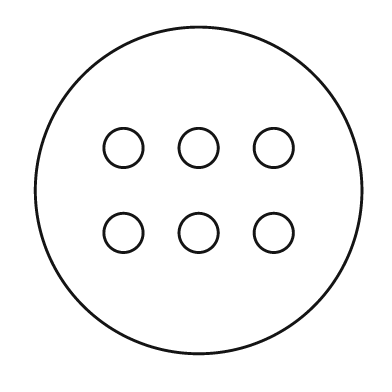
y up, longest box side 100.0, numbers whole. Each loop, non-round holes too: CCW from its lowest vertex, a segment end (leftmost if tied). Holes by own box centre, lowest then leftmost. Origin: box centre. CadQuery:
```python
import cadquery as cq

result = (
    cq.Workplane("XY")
    .moveTo(0.0, 0.0)
    .circle(50.0)
    .moveTo(-23.0, -13.0)
    .circle(6.0)
    .moveTo(0.0, -13.0)
    .circle(6.0)
    .moveTo(23.0, -13.0)
    .circle(6.0)
    .moveTo(-23.0, 13.0)
    .circle(6.0)
    .moveTo(0.0, 13.0)
    .circle(6.0)
    .moveTo(23.0, 13.0)
    .circle(6.0)
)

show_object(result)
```